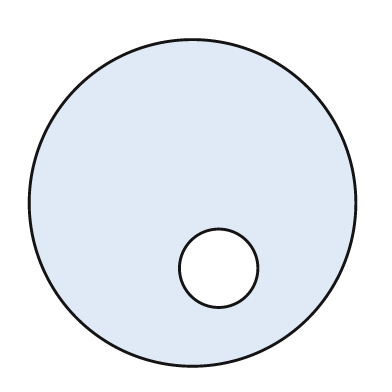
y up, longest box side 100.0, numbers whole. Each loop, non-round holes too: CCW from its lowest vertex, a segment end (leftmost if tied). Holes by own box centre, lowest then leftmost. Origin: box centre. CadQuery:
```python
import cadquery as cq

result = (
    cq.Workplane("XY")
    .moveTo(0.0, 0.0)
    .circle(50.0)
    .moveTo(8.0, -20.0)
    .circle(12.0)
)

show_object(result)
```